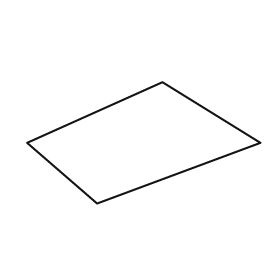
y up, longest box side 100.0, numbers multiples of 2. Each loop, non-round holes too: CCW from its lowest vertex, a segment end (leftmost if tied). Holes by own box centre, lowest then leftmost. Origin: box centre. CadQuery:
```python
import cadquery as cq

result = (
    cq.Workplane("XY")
    .moveTo(-20.0, -26.0)
    .lineTo(50.0, 0.0)
    .lineTo(8.0, 26.0)
    .lineTo(-50.0, 0.0)
    .close()
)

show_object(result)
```